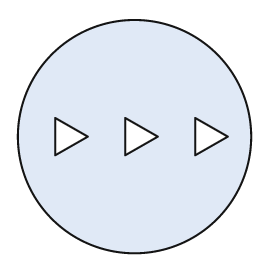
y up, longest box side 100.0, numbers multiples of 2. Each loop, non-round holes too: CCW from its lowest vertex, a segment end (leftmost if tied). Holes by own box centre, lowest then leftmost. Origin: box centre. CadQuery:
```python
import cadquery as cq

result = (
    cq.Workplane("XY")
    .moveTo(0.0, 0.0)
    .circle(50.0)
    .moveTo(-34.0, -8.0)
    .lineTo(-20.0, 0.0)
    .lineTo(-34.0, 8.0)
    .close()
    .moveTo(-4.0, -8.0)
    .lineTo(10.0, 0.0)
    .lineTo(-4.0, 8.0)
    .close()
    .moveTo(26.0, -8.0)
    .lineTo(40.0, 0.0)
    .lineTo(26.0, 8.0)
    .close()
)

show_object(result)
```